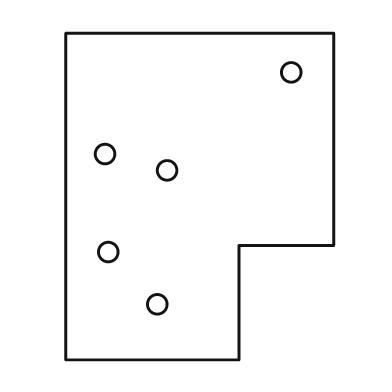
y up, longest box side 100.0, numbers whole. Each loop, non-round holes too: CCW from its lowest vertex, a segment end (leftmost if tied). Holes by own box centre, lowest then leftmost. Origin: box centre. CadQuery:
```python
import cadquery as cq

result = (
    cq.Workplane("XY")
    .moveTo(-41.0, -50.0)
    .lineTo(12.0, -50.0)
    .lineTo(12.0, -15.0)
    .lineTo(41.0, -15.0)
    .lineTo(41.0, 50.0)
    .lineTo(-41.0, 50.0)
    .close()
    .moveTo(-13.0, -33.0)
    .circle(3.0)
    .moveTo(-28.0, -17.0)
    .circle(3.0)
    .moveTo(-10.0, 8.0)
    .circle(3.0)
    .moveTo(-29.0, 13.0)
    .circle(3.0)
    .moveTo(28.0, 38.0)
    .circle(3.0)
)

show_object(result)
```